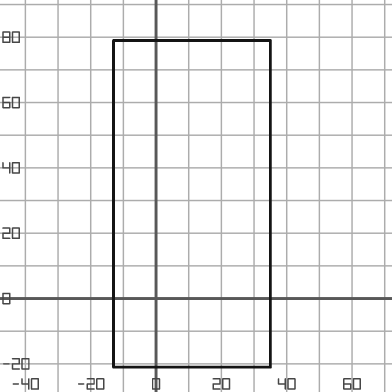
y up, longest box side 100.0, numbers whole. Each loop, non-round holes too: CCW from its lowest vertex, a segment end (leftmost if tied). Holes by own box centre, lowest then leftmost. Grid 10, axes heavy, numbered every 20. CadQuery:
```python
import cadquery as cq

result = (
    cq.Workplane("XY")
    .moveTo(-13.0, -21.0)
    .lineTo(35.0, -21.0)
    .lineTo(35.0, 79.0)
    .lineTo(-13.0, 79.0)
    .close()
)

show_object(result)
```